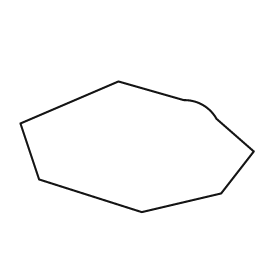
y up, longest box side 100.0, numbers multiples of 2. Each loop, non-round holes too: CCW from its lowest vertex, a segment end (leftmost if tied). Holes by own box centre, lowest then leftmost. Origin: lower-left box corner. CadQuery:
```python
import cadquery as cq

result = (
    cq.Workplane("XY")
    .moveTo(52.0, 0.0)
    .lineTo(86.0, 8.0)
    .lineTo(100.0, 26.0)
    .lineTo(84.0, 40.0)
    .threePointArc((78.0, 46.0), (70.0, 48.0))
    .lineTo(42.0, 56.0)
    .lineTo(0.0, 38.0)
    .lineTo(8.0, 14.0)
    .close()
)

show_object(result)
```